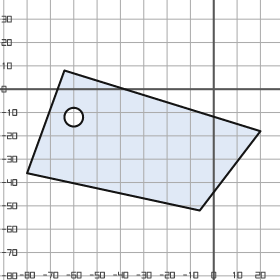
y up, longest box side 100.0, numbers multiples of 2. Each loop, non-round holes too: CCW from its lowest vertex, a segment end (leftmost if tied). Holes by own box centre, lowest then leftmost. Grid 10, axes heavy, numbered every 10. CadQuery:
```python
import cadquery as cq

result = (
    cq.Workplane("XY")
    .moveTo(-6.0, -52.0)
    .lineTo(20.0, -18.0)
    .lineTo(-64.0, 8.0)
    .lineTo(-80.0, -36.0)
    .close()
    .moveTo(-60.0, -12.0)
    .circle(4.0)
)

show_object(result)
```